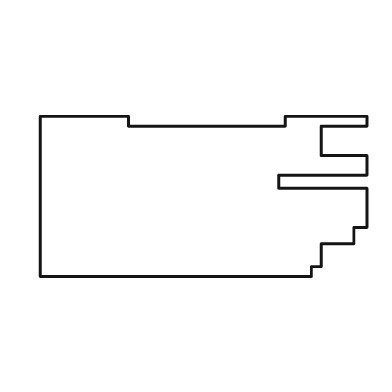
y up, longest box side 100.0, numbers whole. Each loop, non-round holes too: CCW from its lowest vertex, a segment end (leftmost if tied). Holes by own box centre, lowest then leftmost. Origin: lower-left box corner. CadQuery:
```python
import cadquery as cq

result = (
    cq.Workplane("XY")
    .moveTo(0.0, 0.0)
    .lineTo(83.0, 0.0)
    .lineTo(83.0, 3.0)
    .lineTo(86.0, 3.0)
    .lineTo(86.0, 10.0)
    .lineTo(96.0, 10.0)
    .lineTo(96.0, 15.0)
    .lineTo(100.0, 15.0)
    .lineTo(100.0, 27.0)
    .lineTo(73.0, 27.0)
    .lineTo(73.0, 31.0)
    .lineTo(100.0, 31.0)
    .lineTo(100.0, 37.0)
    .lineTo(86.0, 37.0)
    .lineTo(86.0, 46.0)
    .lineTo(100.0, 46.0)
    .lineTo(100.0, 49.0)
    .lineTo(75.0, 49.0)
    .lineTo(75.0, 46.0)
    .lineTo(27.0, 46.0)
    .lineTo(27.0, 49.0)
    .lineTo(0.0, 49.0)
    .close()
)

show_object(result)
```